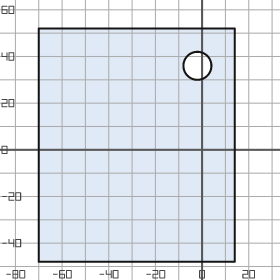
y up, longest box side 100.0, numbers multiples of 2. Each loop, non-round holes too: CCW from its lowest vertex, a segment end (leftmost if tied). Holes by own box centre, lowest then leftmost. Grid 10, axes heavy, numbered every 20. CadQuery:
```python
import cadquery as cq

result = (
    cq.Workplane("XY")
    .moveTo(-70.0, -48.0)
    .lineTo(14.0, -48.0)
    .lineTo(14.0, 52.0)
    .lineTo(-70.0, 52.0)
    .close()
    .moveTo(-2.0, 36.0)
    .circle(6.0)
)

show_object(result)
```